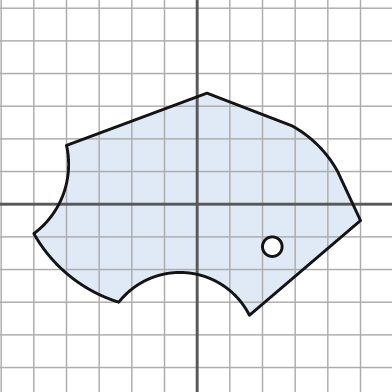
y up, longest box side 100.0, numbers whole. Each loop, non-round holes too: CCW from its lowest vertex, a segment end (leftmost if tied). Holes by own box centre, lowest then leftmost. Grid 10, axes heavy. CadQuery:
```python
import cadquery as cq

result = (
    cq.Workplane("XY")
    .moveTo(16.0, -34.0)
    .lineTo(50.0, -5.0)
    .lineTo(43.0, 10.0)
    .threePointArc((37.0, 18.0), (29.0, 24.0))
    .lineTo(3.0, 34.0)
    .lineTo(-40.0, 18.0)
    .threePointArc((-41.0, 3.0), (-50.0, -9.0))
    .threePointArc((-39.0, -22.0), (-24.0, -30.0))
    .threePointArc((-3.0, -21.0), (16.0, -34.0))
    .close()
    .moveTo(23.0, -13.0)
    .circle(3.0)
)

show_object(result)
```